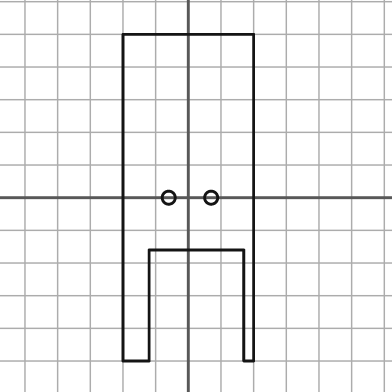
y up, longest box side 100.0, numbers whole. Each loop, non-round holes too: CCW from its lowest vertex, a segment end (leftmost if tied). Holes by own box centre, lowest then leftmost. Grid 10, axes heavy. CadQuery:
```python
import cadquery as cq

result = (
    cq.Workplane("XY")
    .moveTo(-20.0, -50.0)
    .lineTo(-12.0, -50.0)
    .lineTo(-12.0, -16.0)
    .lineTo(17.0, -16.0)
    .lineTo(17.0, -50.0)
    .lineTo(20.0, -50.0)
    .lineTo(20.0, 50.0)
    .lineTo(-20.0, 50.0)
    .close()
    .moveTo(-6.0, 0.0)
    .circle(2.0)
    .moveTo(7.0, 0.0)
    .circle(2.0)
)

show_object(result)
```